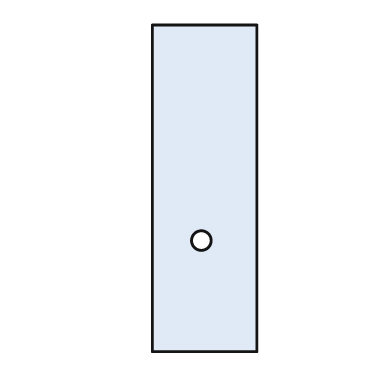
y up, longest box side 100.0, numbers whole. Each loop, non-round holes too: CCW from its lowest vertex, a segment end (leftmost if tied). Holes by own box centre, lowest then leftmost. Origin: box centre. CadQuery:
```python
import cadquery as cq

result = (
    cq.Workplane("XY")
    .moveTo(-16.0, -50.0)
    .lineTo(16.0, -50.0)
    .lineTo(16.0, 50.0)
    .lineTo(-16.0, 50.0)
    .close()
    .moveTo(-1.0, -16.0)
    .circle(3.0)
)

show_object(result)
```